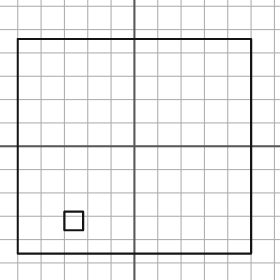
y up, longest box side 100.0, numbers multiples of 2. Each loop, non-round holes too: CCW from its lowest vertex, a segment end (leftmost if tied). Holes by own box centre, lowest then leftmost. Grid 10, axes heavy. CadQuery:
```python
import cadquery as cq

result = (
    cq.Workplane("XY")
    .moveTo(-50.0, -46.0)
    .lineTo(50.0, -46.0)
    .lineTo(50.0, 46.0)
    .lineTo(-50.0, 46.0)
    .close()
    .moveTo(-30.0, -36.0)
    .lineTo(-22.0, -36.0)
    .lineTo(-22.0, -28.0)
    .lineTo(-30.0, -28.0)
    .close()
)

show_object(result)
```